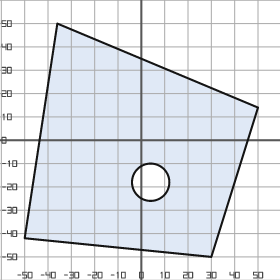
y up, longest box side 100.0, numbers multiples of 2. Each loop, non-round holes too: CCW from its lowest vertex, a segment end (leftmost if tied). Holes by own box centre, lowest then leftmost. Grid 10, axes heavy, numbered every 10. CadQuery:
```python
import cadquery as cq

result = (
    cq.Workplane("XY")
    .moveTo(30.0, -50.0)
    .lineTo(50.0, 14.0)
    .lineTo(-36.0, 50.0)
    .lineTo(-50.0, -42.0)
    .close()
    .moveTo(4.0, -18.0)
    .circle(8.0)
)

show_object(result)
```